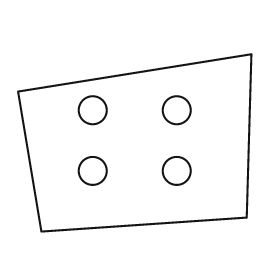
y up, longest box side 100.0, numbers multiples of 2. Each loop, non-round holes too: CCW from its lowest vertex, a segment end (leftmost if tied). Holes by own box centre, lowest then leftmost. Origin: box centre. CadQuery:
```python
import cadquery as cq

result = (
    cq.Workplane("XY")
    .moveTo(-40.0, -38.0)
    .lineTo(48.0, -32.0)
    .lineTo(50.0, 38.0)
    .lineTo(-50.0, 22.0)
    .close()
    .moveTo(-18.0, -12.0)
    .circle(6.0)
    .moveTo(18.0, -12.0)
    .circle(6.0)
    .moveTo(-18.0, 14.0)
    .circle(6.0)
    .moveTo(18.0, 14.0)
    .circle(6.0)
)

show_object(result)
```